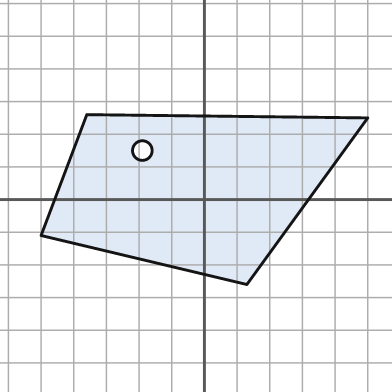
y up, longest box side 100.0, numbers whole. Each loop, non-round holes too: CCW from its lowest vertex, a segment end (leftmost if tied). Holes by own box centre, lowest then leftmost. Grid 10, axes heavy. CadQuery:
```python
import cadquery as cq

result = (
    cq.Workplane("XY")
    .moveTo(13.0, -26.0)
    .lineTo(50.0, 25.0)
    .lineTo(-36.0, 26.0)
    .lineTo(-50.0, -11.0)
    .close()
    .moveTo(-19.0, 15.0)
    .circle(3.0)
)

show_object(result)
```